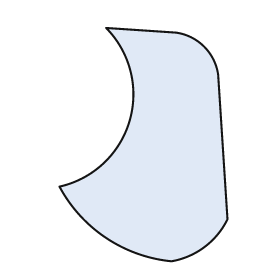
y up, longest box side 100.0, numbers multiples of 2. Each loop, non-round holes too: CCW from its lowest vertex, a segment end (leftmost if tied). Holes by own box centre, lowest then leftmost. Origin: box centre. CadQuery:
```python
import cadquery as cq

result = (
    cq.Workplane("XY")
    .moveTo(12.0, -50.0)
    .threePointArc((26.0, -44.0), (36.0, -32.0))
    .lineTo(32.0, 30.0)
    .threePointArc((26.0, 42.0), (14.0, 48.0))
    .lineTo(-16.0, 50.0)
    .threePointArc((-6.0, 10.0), (-36.0, -18.0))
    .threePointArc((-16.0, -40.0), (12.0, -50.0))
    .close()
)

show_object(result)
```